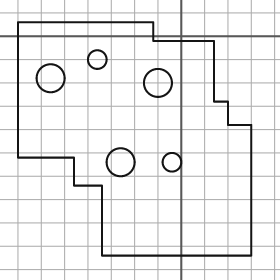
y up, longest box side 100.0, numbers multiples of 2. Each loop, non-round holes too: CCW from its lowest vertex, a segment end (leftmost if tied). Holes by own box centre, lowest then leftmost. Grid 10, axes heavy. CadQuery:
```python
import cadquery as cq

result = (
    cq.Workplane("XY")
    .moveTo(-34.0, -94.0)
    .lineTo(30.0, -94.0)
    .lineTo(30.0, -38.0)
    .lineTo(20.0, -38.0)
    .lineTo(20.0, -28.0)
    .lineTo(14.0, -28.0)
    .lineTo(14.0, -2.0)
    .lineTo(-12.0, -2.0)
    .lineTo(-12.0, 6.0)
    .lineTo(-70.0, 6.0)
    .lineTo(-70.0, -52.0)
    .lineTo(-46.0, -52.0)
    .lineTo(-46.0, -64.0)
    .lineTo(-34.0, -64.0)
    .close()
    .moveTo(-26.0, -54.0)
    .circle(6.0)
    .moveTo(-4.0, -54.0)
    .circle(4.0)
    .moveTo(-10.0, -20.0)
    .circle(6.0)
    .moveTo(-56.0, -18.0)
    .circle(6.0)
    .moveTo(-36.0, -10.0)
    .circle(4.0)
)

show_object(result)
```